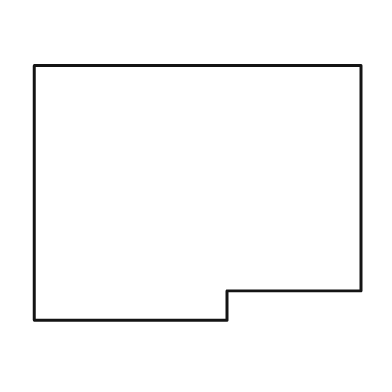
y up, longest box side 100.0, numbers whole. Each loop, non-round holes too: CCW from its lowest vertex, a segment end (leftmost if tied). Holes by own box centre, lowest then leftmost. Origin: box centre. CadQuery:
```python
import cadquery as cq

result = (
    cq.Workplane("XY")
    .moveTo(-50.0, -39.0)
    .lineTo(9.0, -39.0)
    .lineTo(9.0, -30.0)
    .lineTo(50.0, -30.0)
    .lineTo(50.0, 39.0)
    .lineTo(-50.0, 39.0)
    .close()
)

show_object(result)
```